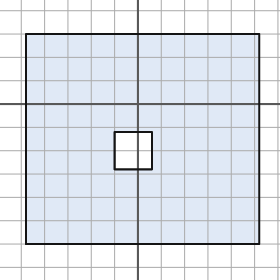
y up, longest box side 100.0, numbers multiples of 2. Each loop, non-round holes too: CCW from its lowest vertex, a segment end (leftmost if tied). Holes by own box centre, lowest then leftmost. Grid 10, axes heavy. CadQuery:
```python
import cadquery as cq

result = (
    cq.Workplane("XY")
    .moveTo(-48.0, -60.0)
    .lineTo(52.0, -60.0)
    .lineTo(52.0, 30.0)
    .lineTo(-48.0, 30.0)
    .close()
    .moveTo(-10.0, -28.0)
    .lineTo(6.0, -28.0)
    .lineTo(6.0, -12.0)
    .lineTo(-10.0, -12.0)
    .close()
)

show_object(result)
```